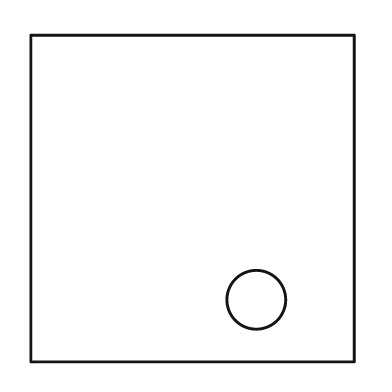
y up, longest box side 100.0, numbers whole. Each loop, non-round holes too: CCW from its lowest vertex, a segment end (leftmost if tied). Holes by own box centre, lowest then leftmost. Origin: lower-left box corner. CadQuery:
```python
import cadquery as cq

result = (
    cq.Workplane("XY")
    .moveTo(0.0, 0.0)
    .lineTo(99.0, 0.0)
    .lineTo(99.0, 100.0)
    .lineTo(0.0, 100.0)
    .close()
    .moveTo(69.0, 19.0)
    .circle(9.0)
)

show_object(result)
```